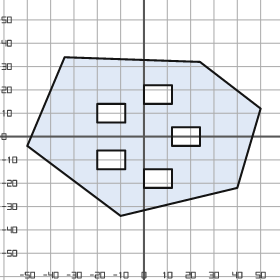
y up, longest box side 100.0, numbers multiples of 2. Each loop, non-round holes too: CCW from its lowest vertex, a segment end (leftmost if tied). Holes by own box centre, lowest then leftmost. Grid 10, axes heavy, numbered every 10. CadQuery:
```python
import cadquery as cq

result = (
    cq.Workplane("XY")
    .moveTo(-10.0, -34.0)
    .lineTo(40.0, -22.0)
    .lineTo(50.0, 12.0)
    .lineTo(24.0, 32.0)
    .lineTo(-34.0, 34.0)
    .lineTo(-50.0, -4.0)
    .close()
    .moveTo(0.0, -22.0)
    .lineTo(12.0, -22.0)
    .lineTo(12.0, -14.0)
    .lineTo(0.0, -14.0)
    .close()
    .moveTo(-20.0, -14.0)
    .lineTo(-8.0, -14.0)
    .lineTo(-8.0, -6.0)
    .lineTo(-20.0, -6.0)
    .close()
    .moveTo(12.0, -4.0)
    .lineTo(24.0, -4.0)
    .lineTo(24.0, 4.0)
    .lineTo(12.0, 4.0)
    .close()
    .moveTo(-20.0, 6.0)
    .lineTo(-8.0, 6.0)
    .lineTo(-8.0, 14.0)
    .lineTo(-20.0, 14.0)
    .close()
    .moveTo(0.0, 14.0)
    .lineTo(12.0, 14.0)
    .lineTo(12.0, 22.0)
    .lineTo(0.0, 22.0)
    .close()
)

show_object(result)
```